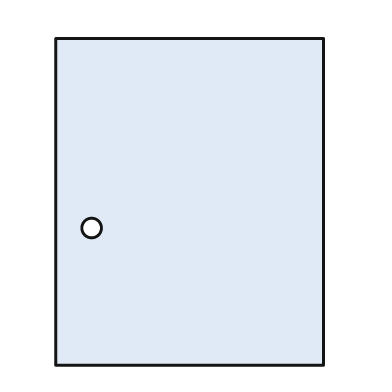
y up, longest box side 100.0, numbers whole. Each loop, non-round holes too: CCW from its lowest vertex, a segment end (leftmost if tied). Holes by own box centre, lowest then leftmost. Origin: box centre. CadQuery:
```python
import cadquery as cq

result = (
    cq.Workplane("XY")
    .moveTo(-41.0, -50.0)
    .lineTo(41.0, -50.0)
    .lineTo(41.0, 50.0)
    .lineTo(-41.0, 50.0)
    .close()
    .moveTo(-30.0, -8.0)
    .circle(3.0)
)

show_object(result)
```